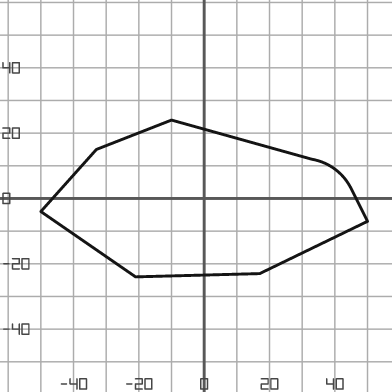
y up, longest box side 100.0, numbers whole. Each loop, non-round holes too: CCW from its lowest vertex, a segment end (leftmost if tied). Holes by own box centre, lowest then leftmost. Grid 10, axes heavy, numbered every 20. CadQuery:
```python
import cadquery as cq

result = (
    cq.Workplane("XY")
    .moveTo(-21.0, -24.0)
    .lineTo(17.0, -23.0)
    .lineTo(50.0, -7.0)
    .lineTo(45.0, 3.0)
    .threePointArc((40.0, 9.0), (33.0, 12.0))
    .lineTo(-10.0, 24.0)
    .lineTo(-33.0, 15.0)
    .lineTo(-50.0, -4.0)
    .close()
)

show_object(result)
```